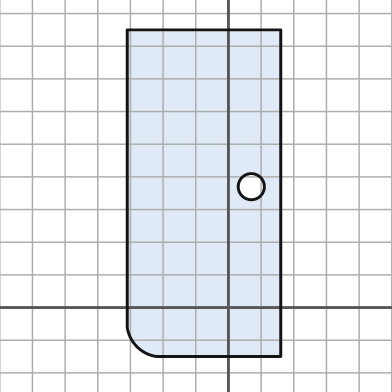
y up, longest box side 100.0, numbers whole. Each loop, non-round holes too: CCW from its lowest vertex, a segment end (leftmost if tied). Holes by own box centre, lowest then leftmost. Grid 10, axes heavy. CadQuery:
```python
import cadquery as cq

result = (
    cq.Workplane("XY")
    .moveTo(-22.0, -15.0)
    .lineTo(16.0, -15.0)
    .lineTo(16.0, 85.0)
    .lineTo(-31.0, 85.0)
    .lineTo(-31.0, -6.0)
    .threePointArc((-28.0, -12.0), (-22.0, -15.0))
    .close()
    .moveTo(7.0, 37.0)
    .circle(4.0)
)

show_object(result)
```